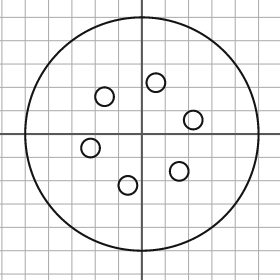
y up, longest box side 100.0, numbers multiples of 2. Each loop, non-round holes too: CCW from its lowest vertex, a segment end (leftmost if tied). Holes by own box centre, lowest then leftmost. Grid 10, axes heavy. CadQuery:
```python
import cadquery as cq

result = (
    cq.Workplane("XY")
    .moveTo(0.0, 0.0)
    .circle(50.0)
    .moveTo(-6.0, -22.0)
    .circle(4.0)
    .moveTo(16.0, -16.0)
    .circle(4.0)
    .moveTo(-22.0, -6.0)
    .circle(4.0)
    .moveTo(22.0, 6.0)
    .circle(4.0)
    .moveTo(-16.0, 16.0)
    .circle(4.0)
    .moveTo(6.0, 22.0)
    .circle(4.0)
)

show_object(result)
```